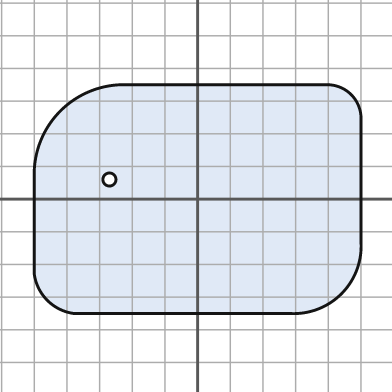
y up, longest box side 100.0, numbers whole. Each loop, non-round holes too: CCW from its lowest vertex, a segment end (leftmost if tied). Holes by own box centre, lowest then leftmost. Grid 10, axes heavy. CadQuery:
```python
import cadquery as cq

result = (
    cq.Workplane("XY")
    .moveTo(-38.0, -35.0)
    .lineTo(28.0, -35.0)
    .threePointArc((44.0, -29.0), (50.0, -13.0))
    .lineTo(50.0, 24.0)
    .threePointArc((47.0, 32.0), (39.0, 35.0))
    .lineTo(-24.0, 35.0)
    .threePointArc((-42.0, 27.0), (-50.0, 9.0))
    .lineTo(-50.0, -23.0)
    .threePointArc((-46.0, -31.0), (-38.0, -35.0))
    .close()
    .moveTo(-27.0, 6.0)
    .circle(2.0)
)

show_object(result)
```